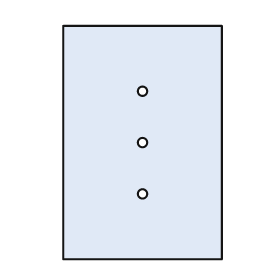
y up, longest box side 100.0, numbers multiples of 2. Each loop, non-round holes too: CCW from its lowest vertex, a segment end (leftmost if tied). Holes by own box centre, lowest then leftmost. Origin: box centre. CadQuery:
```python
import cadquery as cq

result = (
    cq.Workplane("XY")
    .moveTo(-34.0, -50.0)
    .lineTo(34.0, -50.0)
    .lineTo(34.0, 50.0)
    .lineTo(-34.0, 50.0)
    .close()
    .moveTo(0.0, -22.0)
    .circle(2.0)
    .moveTo(0.0, 0.0)
    .circle(2.0)
    .moveTo(0.0, 22.0)
    .circle(2.0)
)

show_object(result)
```